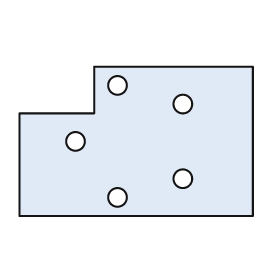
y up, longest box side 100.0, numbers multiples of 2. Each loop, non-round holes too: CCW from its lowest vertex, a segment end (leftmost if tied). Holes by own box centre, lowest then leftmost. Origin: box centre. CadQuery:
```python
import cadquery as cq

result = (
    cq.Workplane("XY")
    .moveTo(-50.0, -32.0)
    .lineTo(50.0, -32.0)
    .lineTo(50.0, 32.0)
    .lineTo(-18.0, 32.0)
    .lineTo(-18.0, 12.0)
    .lineTo(-50.0, 12.0)
    .close()
    .moveTo(-8.0, -24.0)
    .circle(4.0)
    .moveTo(20.0, -16.0)
    .circle(4.0)
    .moveTo(-26.0, 0.0)
    .circle(4.0)
    .moveTo(20.0, 16.0)
    .circle(4.0)
    .moveTo(-8.0, 24.0)
    .circle(4.0)
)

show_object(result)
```